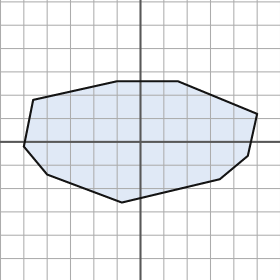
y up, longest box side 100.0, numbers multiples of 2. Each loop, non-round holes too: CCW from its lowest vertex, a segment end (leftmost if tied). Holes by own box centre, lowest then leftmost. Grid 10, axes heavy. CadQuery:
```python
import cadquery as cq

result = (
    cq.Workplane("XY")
    .moveTo(-8.0, -26.0)
    .lineTo(34.0, -16.0)
    .lineTo(46.0, -6.0)
    .lineTo(50.0, 12.0)
    .lineTo(16.0, 26.0)
    .lineTo(-10.0, 26.0)
    .lineTo(-46.0, 18.0)
    .lineTo(-50.0, -2.0)
    .lineTo(-40.0, -14.0)
    .close()
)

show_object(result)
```